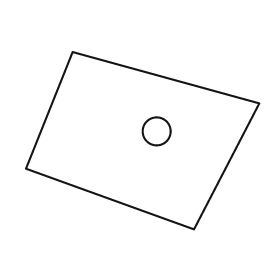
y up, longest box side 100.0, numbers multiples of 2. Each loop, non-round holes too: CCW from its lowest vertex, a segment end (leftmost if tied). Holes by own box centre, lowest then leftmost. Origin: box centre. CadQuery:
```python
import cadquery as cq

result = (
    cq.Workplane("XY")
    .moveTo(22.0, -38.0)
    .lineTo(50.0, 16.0)
    .lineTo(-30.0, 38.0)
    .lineTo(-50.0, -12.0)
    .close()
    .moveTo(6.0, 4.0)
    .circle(6.0)
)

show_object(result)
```